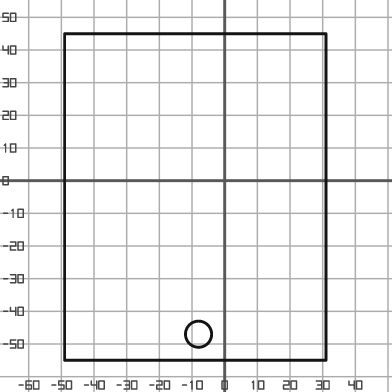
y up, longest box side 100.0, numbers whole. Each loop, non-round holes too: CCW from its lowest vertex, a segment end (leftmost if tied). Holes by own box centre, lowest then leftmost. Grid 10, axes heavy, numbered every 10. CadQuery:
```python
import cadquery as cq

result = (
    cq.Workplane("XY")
    .moveTo(-49.0, -55.0)
    .lineTo(31.0, -55.0)
    .lineTo(31.0, 45.0)
    .lineTo(-49.0, 45.0)
    .close()
    .moveTo(-8.0, -47.0)
    .circle(4.0)
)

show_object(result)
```